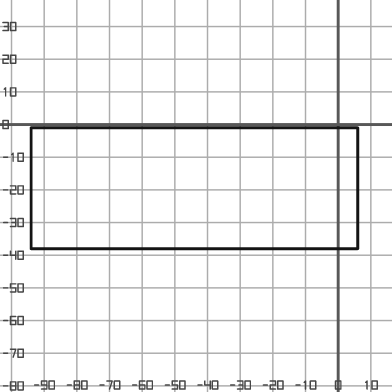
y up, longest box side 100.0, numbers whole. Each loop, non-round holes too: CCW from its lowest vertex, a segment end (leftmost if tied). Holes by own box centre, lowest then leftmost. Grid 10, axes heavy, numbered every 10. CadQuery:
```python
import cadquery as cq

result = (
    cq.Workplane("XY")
    .moveTo(-94.0, -38.0)
    .lineTo(6.0, -38.0)
    .lineTo(6.0, -1.0)
    .lineTo(-94.0, -1.0)
    .close()
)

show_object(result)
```